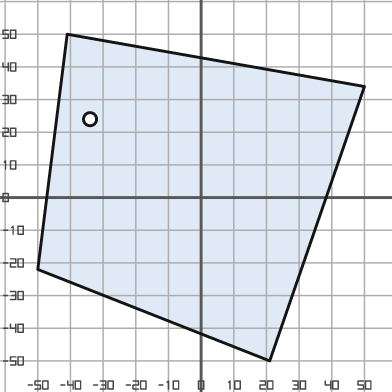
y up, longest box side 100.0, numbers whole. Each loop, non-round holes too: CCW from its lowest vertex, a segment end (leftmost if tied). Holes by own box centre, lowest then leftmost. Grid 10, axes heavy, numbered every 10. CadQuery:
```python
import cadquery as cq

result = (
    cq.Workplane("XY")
    .moveTo(21.0, -50.0)
    .lineTo(50.0, 34.0)
    .lineTo(-41.0, 50.0)
    .lineTo(-50.0, -22.0)
    .close()
    .moveTo(-34.0, 24.0)
    .circle(2.0)
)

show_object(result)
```